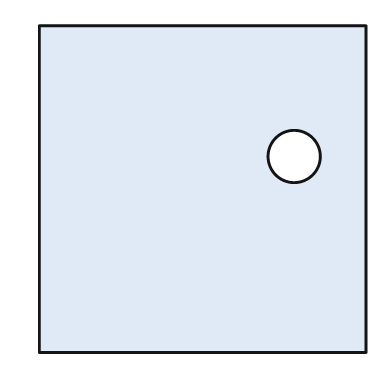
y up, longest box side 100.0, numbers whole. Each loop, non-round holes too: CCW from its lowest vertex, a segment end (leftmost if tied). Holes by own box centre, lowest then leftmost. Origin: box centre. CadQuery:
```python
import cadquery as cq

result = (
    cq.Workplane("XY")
    .moveTo(-50.0, -50.0)
    .lineTo(50.0, -50.0)
    .lineTo(50.0, 50.0)
    .lineTo(-50.0, 50.0)
    .close()
    .moveTo(28.0, 10.0)
    .circle(8.0)
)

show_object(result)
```